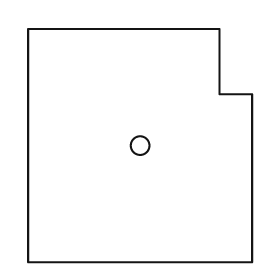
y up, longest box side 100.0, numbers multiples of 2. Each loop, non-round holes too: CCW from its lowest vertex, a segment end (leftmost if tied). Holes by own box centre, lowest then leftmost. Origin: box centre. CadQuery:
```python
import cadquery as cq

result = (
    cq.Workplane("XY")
    .moveTo(-48.0, -50.0)
    .lineTo(48.0, -50.0)
    .lineTo(48.0, 22.0)
    .lineTo(34.0, 22.0)
    .lineTo(34.0, 50.0)
    .lineTo(-48.0, 50.0)
    .close()
    .moveTo(0.0, 0.0)
    .circle(4.0)
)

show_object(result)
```